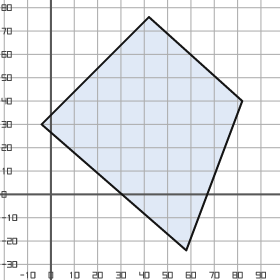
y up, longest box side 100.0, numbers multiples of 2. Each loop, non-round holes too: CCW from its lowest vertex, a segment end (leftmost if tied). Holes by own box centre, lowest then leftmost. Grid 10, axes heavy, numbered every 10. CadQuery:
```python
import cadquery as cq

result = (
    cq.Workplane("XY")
    .moveTo(58.0, -24.0)
    .lineTo(82.0, 40.0)
    .lineTo(42.0, 76.0)
    .lineTo(-4.0, 30.0)
    .close()
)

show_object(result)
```